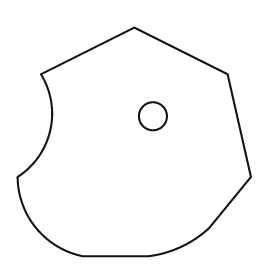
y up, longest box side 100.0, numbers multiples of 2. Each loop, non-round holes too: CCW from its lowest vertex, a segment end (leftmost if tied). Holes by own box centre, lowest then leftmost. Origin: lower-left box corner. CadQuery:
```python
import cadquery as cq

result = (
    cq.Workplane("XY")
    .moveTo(28.0, 0.0)
    .lineTo(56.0, 0.0)
    .threePointArc((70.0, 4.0), (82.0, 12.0))
    .lineTo(100.0, 34.0)
    .lineTo(90.0, 78.0)
    .lineTo(50.0, 98.0)
    .lineTo(10.0, 78.0)
    .threePointArc((14.0, 54.0), (0.0, 34.0))
    .threePointArc((8.0, 12.0), (28.0, 0.0))
    .close()
    .moveTo(58.0, 60.0)
    .circle(6.0)
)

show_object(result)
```